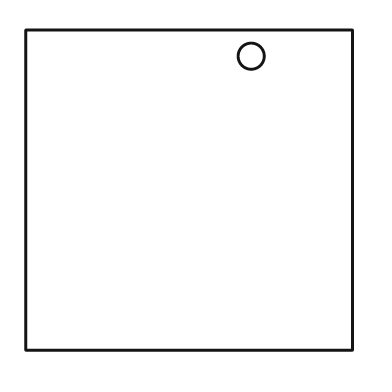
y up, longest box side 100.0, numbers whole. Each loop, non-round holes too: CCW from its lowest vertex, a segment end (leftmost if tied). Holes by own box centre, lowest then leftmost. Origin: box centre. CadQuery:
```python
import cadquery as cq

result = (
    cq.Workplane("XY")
    .moveTo(-50.0, -49.0)
    .lineTo(50.0, -49.0)
    .lineTo(50.0, 49.0)
    .lineTo(-50.0, 49.0)
    .close()
    .moveTo(19.0, 41.0)
    .circle(4.0)
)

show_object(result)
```